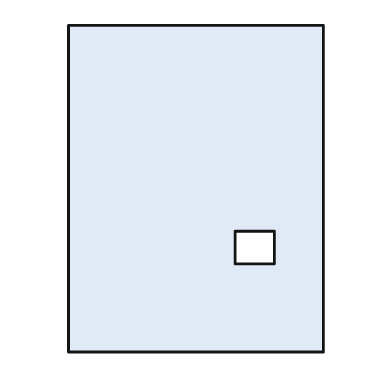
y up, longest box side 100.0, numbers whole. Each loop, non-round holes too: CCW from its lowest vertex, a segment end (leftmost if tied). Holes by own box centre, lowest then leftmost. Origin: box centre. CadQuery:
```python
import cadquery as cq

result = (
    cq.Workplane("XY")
    .moveTo(-39.0, -50.0)
    .lineTo(39.0, -50.0)
    .lineTo(39.0, 50.0)
    .lineTo(-39.0, 50.0)
    .close()
    .moveTo(12.0, -23.0)
    .lineTo(24.0, -23.0)
    .lineTo(24.0, -13.0)
    .lineTo(12.0, -13.0)
    .close()
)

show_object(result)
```